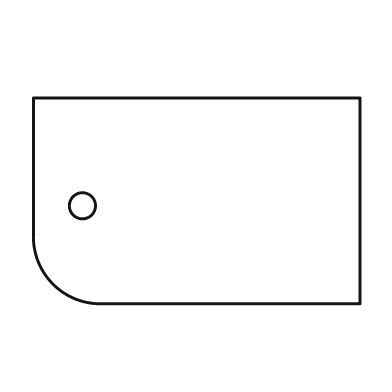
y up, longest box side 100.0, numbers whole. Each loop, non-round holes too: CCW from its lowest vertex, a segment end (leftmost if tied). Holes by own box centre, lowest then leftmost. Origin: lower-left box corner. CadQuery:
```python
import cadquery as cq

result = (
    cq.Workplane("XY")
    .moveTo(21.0, 0.0)
    .lineTo(100.0, 0.0)
    .lineTo(100.0, 63.0)
    .lineTo(0.0, 63.0)
    .lineTo(0.0, 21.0)
    .threePointArc((6.0, 6.0), (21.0, 0.0))
    .close()
    .moveTo(15.0, 30.0)
    .circle(4.0)
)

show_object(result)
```